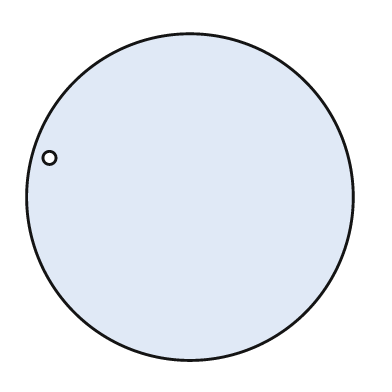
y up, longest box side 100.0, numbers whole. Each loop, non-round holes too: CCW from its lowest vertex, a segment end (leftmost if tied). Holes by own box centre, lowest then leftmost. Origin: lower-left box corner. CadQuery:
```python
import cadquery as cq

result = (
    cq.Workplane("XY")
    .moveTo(50.0, 50.0)
    .circle(50.0)
    .moveTo(7.0, 62.0)
    .circle(2.0)
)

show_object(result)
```